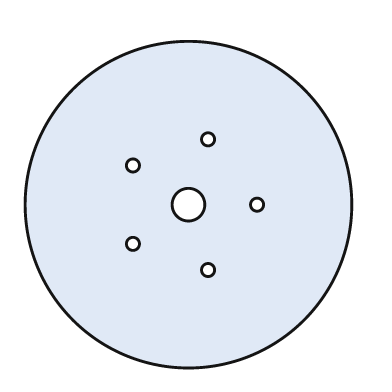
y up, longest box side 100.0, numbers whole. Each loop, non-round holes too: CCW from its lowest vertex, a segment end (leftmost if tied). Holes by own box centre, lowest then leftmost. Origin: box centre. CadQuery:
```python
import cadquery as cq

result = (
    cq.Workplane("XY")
    .moveTo(0.0, 0.0)
    .circle(50.0)
    .moveTo(6.0, -20.0)
    .circle(2.0)
    .moveTo(-17.0, -12.0)
    .circle(2.0)
    .moveTo(0.0, 0.0)
    .circle(5.0)
    .moveTo(21.0, 0.0)
    .circle(2.0)
    .moveTo(-17.0, 12.0)
    .circle(2.0)
    .moveTo(6.0, 20.0)
    .circle(2.0)
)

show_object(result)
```